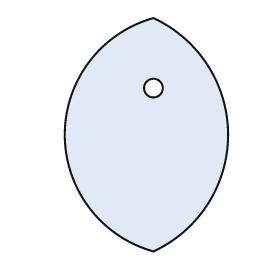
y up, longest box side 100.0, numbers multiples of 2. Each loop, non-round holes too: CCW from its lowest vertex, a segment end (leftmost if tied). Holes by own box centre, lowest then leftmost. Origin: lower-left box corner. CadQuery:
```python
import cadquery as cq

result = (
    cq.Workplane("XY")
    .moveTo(38.0, 0.0)
    .threePointArc((70.0, 50.0), (38.0, 100.0))
    .threePointArc((0.0, 50.0), (38.0, 0.0))
    .close()
    .moveTo(38.0, 70.0)
    .circle(4.0)
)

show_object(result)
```